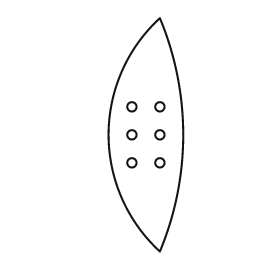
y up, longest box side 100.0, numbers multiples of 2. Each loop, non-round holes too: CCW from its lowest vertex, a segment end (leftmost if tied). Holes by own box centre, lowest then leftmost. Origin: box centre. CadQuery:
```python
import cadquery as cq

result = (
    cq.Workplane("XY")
    .moveTo(6.0, -50.0)
    .threePointArc((16.0, 0.0), (6.0, 50.0))
    .threePointArc((-16.0, 0.0), (6.0, -50.0))
    .close()
    .moveTo(-6.0, -12.0)
    .circle(2.0)
    .moveTo(6.0, -12.0)
    .circle(2.0)
    .moveTo(-6.0, 0.0)
    .circle(2.0)
    .moveTo(6.0, 0.0)
    .circle(2.0)
    .moveTo(-6.0, 12.0)
    .circle(2.0)
    .moveTo(6.0, 12.0)
    .circle(2.0)
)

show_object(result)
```